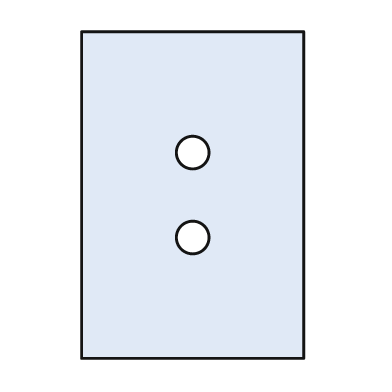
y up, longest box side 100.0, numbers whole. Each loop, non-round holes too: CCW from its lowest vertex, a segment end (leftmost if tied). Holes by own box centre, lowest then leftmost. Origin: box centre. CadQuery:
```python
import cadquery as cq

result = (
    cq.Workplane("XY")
    .moveTo(-34.0, -50.0)
    .lineTo(34.0, -50.0)
    .lineTo(34.0, 50.0)
    .lineTo(-34.0, 50.0)
    .close()
    .moveTo(0.0, -13.0)
    .circle(5.0)
    .moveTo(0.0, 13.0)
    .circle(5.0)
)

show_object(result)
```